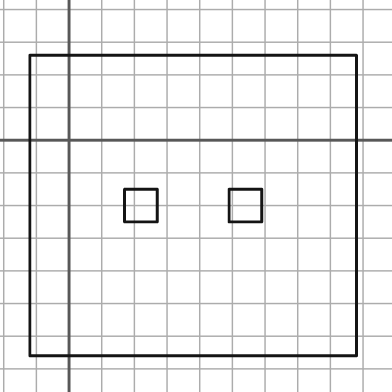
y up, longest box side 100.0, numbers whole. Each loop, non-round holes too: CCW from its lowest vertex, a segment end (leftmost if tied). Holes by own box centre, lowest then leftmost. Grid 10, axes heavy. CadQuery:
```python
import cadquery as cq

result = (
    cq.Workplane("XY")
    .moveTo(-12.0, -66.0)
    .lineTo(88.0, -66.0)
    .lineTo(88.0, 26.0)
    .lineTo(-12.0, 26.0)
    .close()
    .moveTo(17.0, -25.0)
    .lineTo(27.0, -25.0)
    .lineTo(27.0, -15.0)
    .lineTo(17.0, -15.0)
    .close()
    .moveTo(49.0, -25.0)
    .lineTo(59.0, -25.0)
    .lineTo(59.0, -15.0)
    .lineTo(49.0, -15.0)
    .close()
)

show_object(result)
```